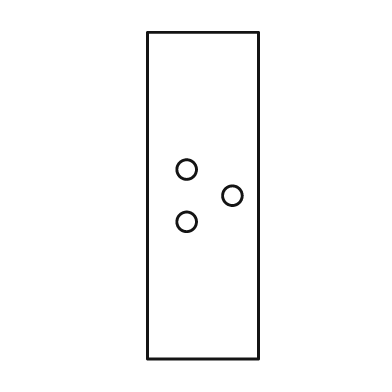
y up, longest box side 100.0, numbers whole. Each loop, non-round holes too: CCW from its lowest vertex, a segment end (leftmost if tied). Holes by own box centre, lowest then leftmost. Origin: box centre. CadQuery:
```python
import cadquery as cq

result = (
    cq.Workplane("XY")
    .moveTo(-17.0, -50.0)
    .lineTo(17.0, -50.0)
    .lineTo(17.0, 50.0)
    .lineTo(-17.0, 50.0)
    .close()
    .moveTo(-5.0, -8.0)
    .circle(3.0)
    .moveTo(9.0, 0.0)
    .circle(3.0)
    .moveTo(-5.0, 8.0)
    .circle(3.0)
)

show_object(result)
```